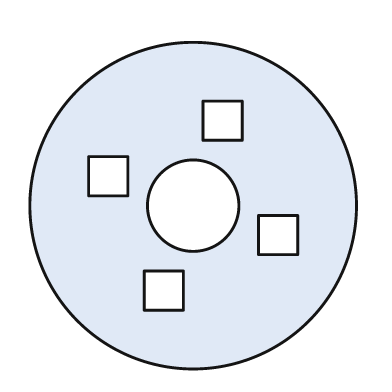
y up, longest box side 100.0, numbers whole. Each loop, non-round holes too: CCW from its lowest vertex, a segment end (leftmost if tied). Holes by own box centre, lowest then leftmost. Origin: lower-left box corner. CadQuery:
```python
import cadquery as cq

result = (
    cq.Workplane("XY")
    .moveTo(50.0, 50.0)
    .circle(50.0)
    .moveTo(35.0, 18.0)
    .lineTo(47.0, 18.0)
    .lineTo(47.0, 30.0)
    .lineTo(35.0, 30.0)
    .close()
    .moveTo(70.0, 35.0)
    .lineTo(82.0, 35.0)
    .lineTo(82.0, 47.0)
    .lineTo(70.0, 47.0)
    .close()
    .moveTo(50.0, 50.0)
    .circle(14.0)
    .moveTo(18.0, 53.0)
    .lineTo(30.0, 53.0)
    .lineTo(30.0, 65.0)
    .lineTo(18.0, 65.0)
    .close()
    .moveTo(53.0, 70.0)
    .lineTo(65.0, 70.0)
    .lineTo(65.0, 82.0)
    .lineTo(53.0, 82.0)
    .close()
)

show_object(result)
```